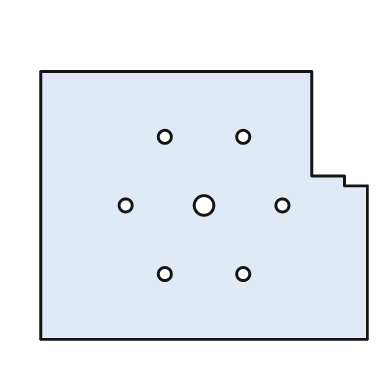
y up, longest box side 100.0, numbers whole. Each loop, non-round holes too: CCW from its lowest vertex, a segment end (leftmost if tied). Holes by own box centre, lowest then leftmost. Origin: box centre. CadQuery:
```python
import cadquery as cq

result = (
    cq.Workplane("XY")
    .moveTo(-50.0, -41.0)
    .lineTo(50.0, -41.0)
    .lineTo(50.0, 6.0)
    .lineTo(43.0, 6.0)
    .lineTo(43.0, 9.0)
    .lineTo(33.0, 9.0)
    .lineTo(33.0, 41.0)
    .lineTo(-50.0, 41.0)
    .close()
    .moveTo(-12.0, -21.0)
    .circle(2.0)
    .moveTo(12.0, -21.0)
    .circle(2.0)
    .moveTo(-24.0, 0.0)
    .circle(2.0)
    .moveTo(0.0, 0.0)
    .circle(3.0)
    .moveTo(24.0, 0.0)
    .circle(2.0)
    .moveTo(-12.0, 21.0)
    .circle(2.0)
    .moveTo(12.0, 21.0)
    .circle(2.0)
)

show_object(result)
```